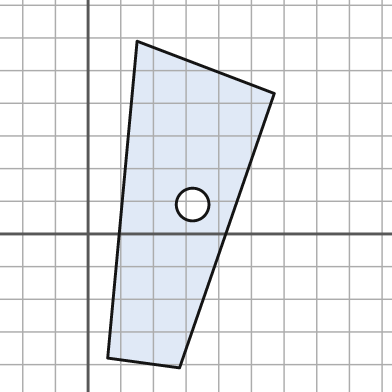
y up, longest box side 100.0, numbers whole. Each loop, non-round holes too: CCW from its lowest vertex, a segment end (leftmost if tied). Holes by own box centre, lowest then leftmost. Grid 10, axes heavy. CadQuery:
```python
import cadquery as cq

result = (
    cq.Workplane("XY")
    .moveTo(28.0, -41.0)
    .lineTo(57.0, 43.0)
    .lineTo(15.0, 59.0)
    .lineTo(6.0, -38.0)
    .close()
    .moveTo(32.0, 9.0)
    .circle(5.0)
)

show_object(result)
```